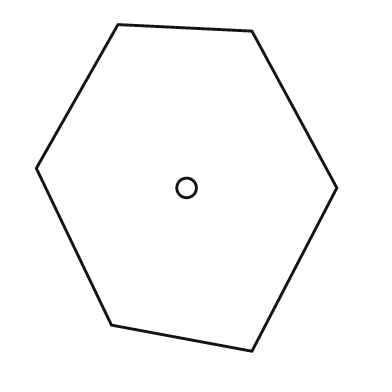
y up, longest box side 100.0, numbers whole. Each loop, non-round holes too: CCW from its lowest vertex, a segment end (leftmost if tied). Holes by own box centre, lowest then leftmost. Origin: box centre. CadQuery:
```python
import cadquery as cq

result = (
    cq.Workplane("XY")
    .moveTo(20.0, -50.0)
    .lineTo(46.0, 0.0)
    .lineTo(20.0, 48.0)
    .lineTo(-21.0, 50.0)
    .lineTo(-46.0, 6.0)
    .lineTo(-23.0, -42.0)
    .close()
    .moveTo(0.0, 0.0)
    .circle(3.0)
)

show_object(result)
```